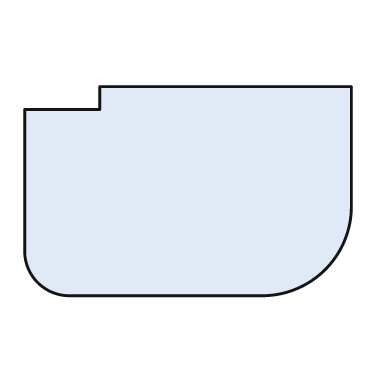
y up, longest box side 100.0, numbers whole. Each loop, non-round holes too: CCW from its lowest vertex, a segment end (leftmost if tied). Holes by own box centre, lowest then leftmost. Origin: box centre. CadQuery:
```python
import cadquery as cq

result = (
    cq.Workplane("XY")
    .moveTo(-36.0, -32.0)
    .lineTo(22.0, -32.0)
    .threePointArc((42.0, -24.0), (50.0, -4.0))
    .lineTo(50.0, 32.0)
    .lineTo(-27.0, 32.0)
    .lineTo(-27.0, 25.0)
    .lineTo(-50.0, 25.0)
    .lineTo(-50.0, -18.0)
    .threePointArc((-46.0, -28.0), (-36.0, -32.0))
    .close()
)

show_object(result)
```